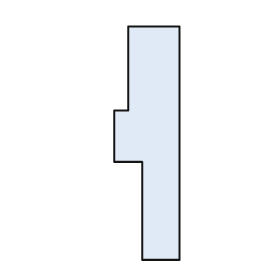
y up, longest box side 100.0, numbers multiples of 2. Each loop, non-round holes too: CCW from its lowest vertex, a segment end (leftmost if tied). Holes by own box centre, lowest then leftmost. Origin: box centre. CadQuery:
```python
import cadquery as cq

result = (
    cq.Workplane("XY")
    .moveTo(-2.0, -50.0)
    .lineTo(14.0, -50.0)
    .lineTo(14.0, 50.0)
    .lineTo(-8.0, 50.0)
    .lineTo(-8.0, 14.0)
    .lineTo(-14.0, 14.0)
    .lineTo(-14.0, -8.0)
    .lineTo(-2.0, -8.0)
    .close()
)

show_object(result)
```